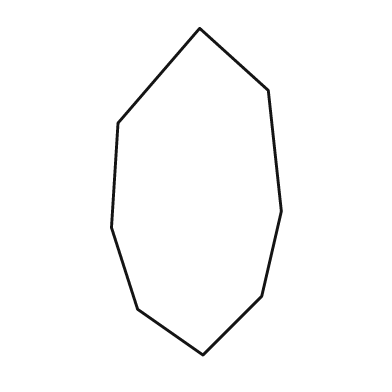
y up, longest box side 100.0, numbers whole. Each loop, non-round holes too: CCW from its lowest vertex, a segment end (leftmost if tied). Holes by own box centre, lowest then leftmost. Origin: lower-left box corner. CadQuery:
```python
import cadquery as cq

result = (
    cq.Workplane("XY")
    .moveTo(28.0, 0.0)
    .lineTo(46.0, 18.0)
    .lineTo(52.0, 44.0)
    .lineTo(48.0, 81.0)
    .lineTo(27.0, 100.0)
    .lineTo(2.0, 71.0)
    .lineTo(0.0, 39.0)
    .lineTo(8.0, 14.0)
    .close()
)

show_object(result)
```